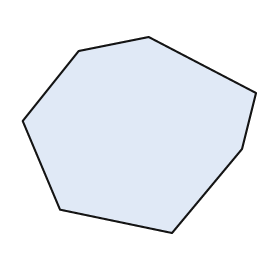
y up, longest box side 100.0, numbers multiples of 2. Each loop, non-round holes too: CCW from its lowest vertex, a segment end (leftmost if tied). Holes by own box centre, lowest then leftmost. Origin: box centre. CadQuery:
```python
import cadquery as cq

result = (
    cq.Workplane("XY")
    .moveTo(14.0, -42.0)
    .lineTo(44.0, -6.0)
    .lineTo(50.0, 18.0)
    .lineTo(4.0, 42.0)
    .lineTo(-26.0, 36.0)
    .lineTo(-50.0, 6.0)
    .lineTo(-34.0, -32.0)
    .close()
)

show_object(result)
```